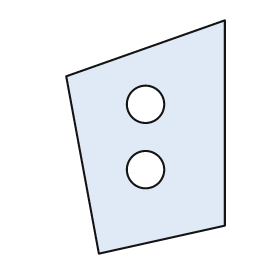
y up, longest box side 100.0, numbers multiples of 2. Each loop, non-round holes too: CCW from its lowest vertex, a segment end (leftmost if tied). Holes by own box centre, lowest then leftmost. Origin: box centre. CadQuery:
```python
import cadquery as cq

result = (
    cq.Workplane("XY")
    .moveTo(-20.0, -50.0)
    .lineTo(34.0, -38.0)
    .lineTo(34.0, 50.0)
    .lineTo(-34.0, 26.0)
    .close()
    .moveTo(0.0, -14.0)
    .circle(8.0)
    .moveTo(0.0, 14.0)
    .circle(8.0)
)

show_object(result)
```